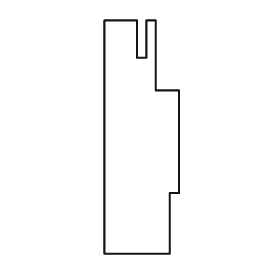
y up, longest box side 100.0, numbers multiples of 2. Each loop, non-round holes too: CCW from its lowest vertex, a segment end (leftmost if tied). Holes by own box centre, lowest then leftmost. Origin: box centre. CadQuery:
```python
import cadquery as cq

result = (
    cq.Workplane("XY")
    .moveTo(-16.0, -50.0)
    .lineTo(12.0, -50.0)
    .lineTo(12.0, -24.0)
    .lineTo(16.0, -24.0)
    .lineTo(16.0, 20.0)
    .lineTo(6.0, 20.0)
    .lineTo(6.0, 50.0)
    .lineTo(2.0, 50.0)
    .lineTo(2.0, 34.0)
    .lineTo(-2.0, 34.0)
    .lineTo(-2.0, 50.0)
    .lineTo(-16.0, 50.0)
    .close()
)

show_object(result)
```